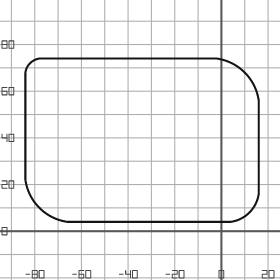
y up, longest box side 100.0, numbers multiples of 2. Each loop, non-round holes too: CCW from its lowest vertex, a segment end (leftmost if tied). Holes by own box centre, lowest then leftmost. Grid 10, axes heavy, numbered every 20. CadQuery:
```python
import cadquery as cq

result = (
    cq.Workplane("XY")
    .moveTo(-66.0, 4.0)
    .lineTo(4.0, 4.0)
    .threePointArc((12.0, 8.0), (16.0, 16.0))
    .lineTo(16.0, 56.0)
    .threePointArc((10.0, 68.0), (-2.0, 74.0))
    .lineTo(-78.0, 74.0)
    .threePointArc((-82.0, 72.0), (-84.0, 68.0))
    .lineTo(-84.0, 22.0)
    .threePointArc((-78.0, 10.0), (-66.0, 4.0))
    .close()
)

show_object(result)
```